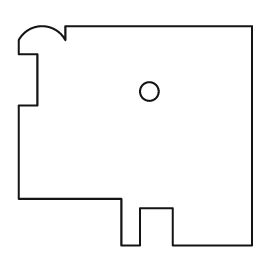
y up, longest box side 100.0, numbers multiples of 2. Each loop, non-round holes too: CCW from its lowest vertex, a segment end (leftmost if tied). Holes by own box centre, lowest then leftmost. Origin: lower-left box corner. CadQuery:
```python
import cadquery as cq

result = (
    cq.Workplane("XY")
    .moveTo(44.0, 0.0)
    .lineTo(52.0, 0.0)
    .lineTo(52.0, 16.0)
    .lineTo(66.0, 16.0)
    .lineTo(66.0, 0.0)
    .lineTo(100.0, 0.0)
    .lineTo(100.0, 94.0)
    .lineTo(20.0, 94.0)
    .lineTo(20.0, 88.0)
    .threePointArc((10.0, 94.0), (0.0, 88.0))
    .lineTo(0.0, 82.0)
    .lineTo(8.0, 82.0)
    .lineTo(8.0, 60.0)
    .lineTo(0.0, 60.0)
    .lineTo(0.0, 20.0)
    .lineTo(44.0, 20.0)
    .close()
    .moveTo(56.0, 66.0)
    .circle(4.0)
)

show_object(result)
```